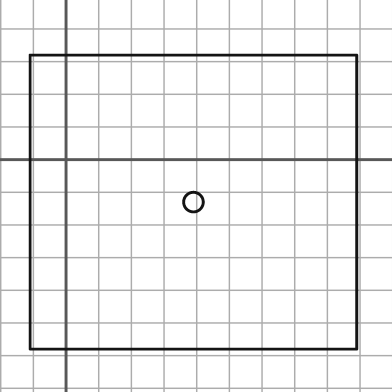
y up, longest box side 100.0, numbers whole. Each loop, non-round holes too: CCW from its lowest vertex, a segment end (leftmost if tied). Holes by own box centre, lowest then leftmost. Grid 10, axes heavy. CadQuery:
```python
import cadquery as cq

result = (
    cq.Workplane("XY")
    .moveTo(-11.0, -58.0)
    .lineTo(89.0, -58.0)
    .lineTo(89.0, 32.0)
    .lineTo(-11.0, 32.0)
    .close()
    .moveTo(39.0, -13.0)
    .circle(3.0)
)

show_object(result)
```